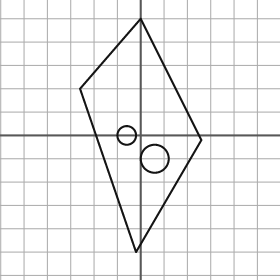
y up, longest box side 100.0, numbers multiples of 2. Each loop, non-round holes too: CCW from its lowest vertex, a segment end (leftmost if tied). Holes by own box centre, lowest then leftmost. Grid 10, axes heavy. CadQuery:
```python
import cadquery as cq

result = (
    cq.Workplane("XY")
    .moveTo(-2.0, -50.0)
    .lineTo(26.0, -2.0)
    .lineTo(0.0, 50.0)
    .lineTo(-26.0, 20.0)
    .close()
    .moveTo(6.0, -10.0)
    .circle(6.0)
    .moveTo(-6.0, 0.0)
    .circle(4.0)
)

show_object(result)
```